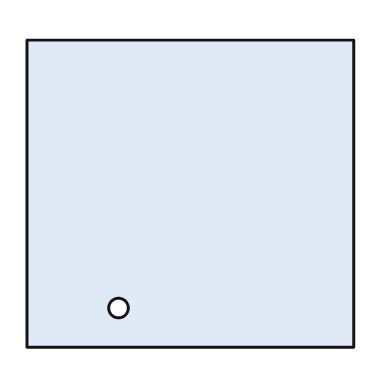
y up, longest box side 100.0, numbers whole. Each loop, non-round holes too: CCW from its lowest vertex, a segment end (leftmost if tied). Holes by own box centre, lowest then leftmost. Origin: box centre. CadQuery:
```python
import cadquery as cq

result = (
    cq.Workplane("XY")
    .moveTo(-50.0, -47.0)
    .lineTo(50.0, -47.0)
    .lineTo(50.0, 47.0)
    .lineTo(-50.0, 47.0)
    .close()
    .moveTo(-22.0, -35.0)
    .circle(3.0)
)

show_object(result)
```